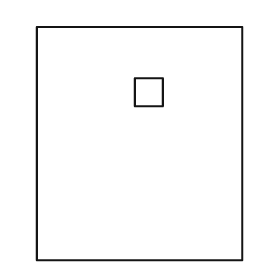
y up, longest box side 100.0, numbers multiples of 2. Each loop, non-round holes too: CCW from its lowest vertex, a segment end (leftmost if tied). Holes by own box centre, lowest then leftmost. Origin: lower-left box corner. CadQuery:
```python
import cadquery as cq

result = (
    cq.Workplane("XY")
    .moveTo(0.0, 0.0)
    .lineTo(88.0, 0.0)
    .lineTo(88.0, 100.0)
    .lineTo(0.0, 100.0)
    .close()
    .moveTo(42.0, 66.0)
    .lineTo(54.0, 66.0)
    .lineTo(54.0, 78.0)
    .lineTo(42.0, 78.0)
    .close()
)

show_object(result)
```